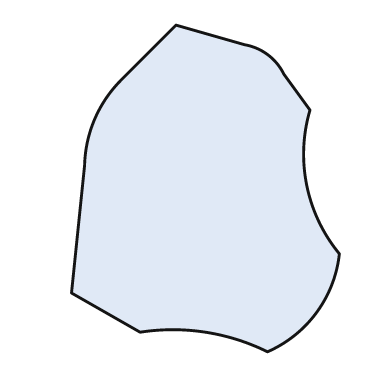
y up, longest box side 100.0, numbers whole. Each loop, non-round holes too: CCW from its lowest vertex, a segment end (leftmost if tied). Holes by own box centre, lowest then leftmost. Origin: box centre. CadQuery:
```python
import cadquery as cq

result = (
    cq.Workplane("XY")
    .moveTo(19.0, -50.0)
    .threePointArc((34.0, -38.0), (41.0, -20.0))
    .threePointArc((31.0, 1.0), (32.0, 24.0))
    .lineTo(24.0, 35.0)
    .threePointArc((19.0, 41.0), (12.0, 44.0))
    .lineTo(-9.0, 50.0)
    .lineTo(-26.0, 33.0)
    .threePointArc((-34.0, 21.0), (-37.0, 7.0))
    .lineTo(-41.0, -32.0)
    .lineTo(-20.0, -44.0)
    .threePointArc((0.0, -44.0), (19.0, -50.0))
    .close()
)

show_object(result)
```